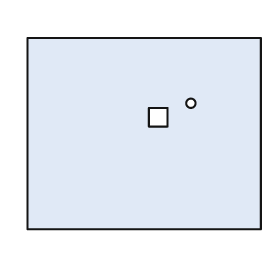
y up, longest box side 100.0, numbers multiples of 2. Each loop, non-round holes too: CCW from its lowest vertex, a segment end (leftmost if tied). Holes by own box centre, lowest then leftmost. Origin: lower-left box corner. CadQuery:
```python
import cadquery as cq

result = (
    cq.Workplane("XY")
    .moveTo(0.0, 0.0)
    .lineTo(100.0, 0.0)
    .lineTo(100.0, 82.0)
    .lineTo(0.0, 82.0)
    .close()
    .moveTo(52.0, 44.0)
    .lineTo(60.0, 44.0)
    .lineTo(60.0, 52.0)
    .lineTo(52.0, 52.0)
    .close()
    .moveTo(70.0, 54.0)
    .circle(2.0)
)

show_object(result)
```